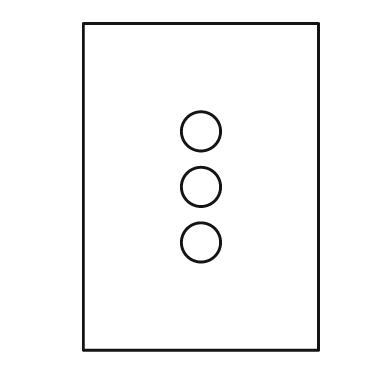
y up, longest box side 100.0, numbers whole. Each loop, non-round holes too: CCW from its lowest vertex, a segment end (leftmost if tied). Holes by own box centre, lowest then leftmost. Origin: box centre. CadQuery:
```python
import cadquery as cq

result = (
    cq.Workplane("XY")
    .moveTo(-36.0, -50.0)
    .lineTo(36.0, -50.0)
    .lineTo(36.0, 50.0)
    .lineTo(-36.0, 50.0)
    .close()
    .moveTo(0.0, -17.0)
    .circle(6.0)
    .moveTo(0.0, 0.0)
    .circle(6.0)
    .moveTo(0.0, 17.0)
    .circle(6.0)
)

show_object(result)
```